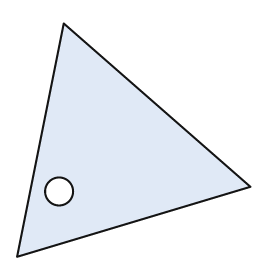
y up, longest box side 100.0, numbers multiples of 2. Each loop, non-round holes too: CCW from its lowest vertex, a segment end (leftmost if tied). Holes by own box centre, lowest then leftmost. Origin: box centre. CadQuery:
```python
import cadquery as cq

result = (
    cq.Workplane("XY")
    .moveTo(-50.0, -50.0)
    .lineTo(50.0, -20.0)
    .lineTo(-30.0, 50.0)
    .close()
    .moveTo(-32.0, -22.0)
    .circle(6.0)
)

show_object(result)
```